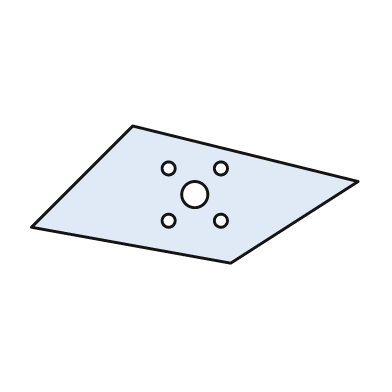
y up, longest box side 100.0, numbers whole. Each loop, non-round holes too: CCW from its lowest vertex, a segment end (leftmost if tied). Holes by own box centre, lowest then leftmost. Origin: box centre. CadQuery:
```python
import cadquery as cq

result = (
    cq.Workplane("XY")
    .moveTo(11.0, -21.0)
    .lineTo(50.0, 4.0)
    .lineTo(-19.0, 21.0)
    .lineTo(-50.0, -10.0)
    .close()
    .moveTo(-8.0, -8.0)
    .circle(2.0)
    .moveTo(8.0, -8.0)
    .circle(2.0)
    .moveTo(0.0, 0.0)
    .circle(4.0)
    .moveTo(-8.0, 8.0)
    .circle(2.0)
    .moveTo(8.0, 8.0)
    .circle(2.0)
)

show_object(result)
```